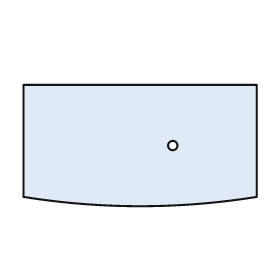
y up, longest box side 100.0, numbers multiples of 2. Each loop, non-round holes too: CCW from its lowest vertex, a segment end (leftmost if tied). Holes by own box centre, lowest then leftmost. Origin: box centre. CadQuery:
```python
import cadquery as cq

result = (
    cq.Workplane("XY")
    .moveTo(-50.0, -22.0)
    .threePointArc((0.0, -26.0), (50.0, -22.0))
    .lineTo(50.0, 26.0)
    .lineTo(-50.0, 26.0)
    .close()
    .moveTo(14.0, 0.0)
    .circle(2.0)
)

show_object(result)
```